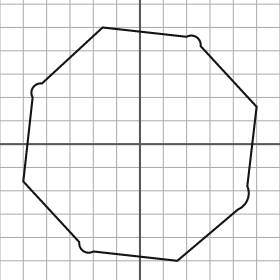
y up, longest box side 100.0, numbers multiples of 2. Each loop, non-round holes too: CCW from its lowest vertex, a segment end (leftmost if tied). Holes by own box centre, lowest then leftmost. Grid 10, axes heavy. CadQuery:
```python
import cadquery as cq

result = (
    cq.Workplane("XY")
    .moveTo(16.0, -50.0)
    .lineTo(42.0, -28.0)
    .threePointArc((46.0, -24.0), (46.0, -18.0))
    .lineTo(50.0, 16.0)
    .lineTo(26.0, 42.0)
    .threePointArc((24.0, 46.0), (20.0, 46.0))
    .lineTo(-16.0, 50.0)
    .lineTo(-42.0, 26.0)
    .threePointArc((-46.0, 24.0), (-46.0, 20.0))
    .lineTo(-50.0, -16.0)
    .lineTo(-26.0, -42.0)
    .threePointArc((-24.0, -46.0), (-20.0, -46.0))
    .close()
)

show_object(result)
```